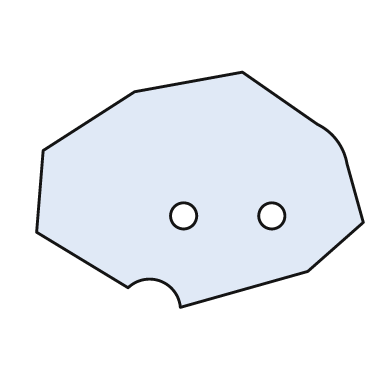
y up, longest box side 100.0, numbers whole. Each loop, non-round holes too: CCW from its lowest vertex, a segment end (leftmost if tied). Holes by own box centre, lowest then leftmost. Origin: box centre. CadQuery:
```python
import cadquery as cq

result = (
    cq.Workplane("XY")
    .moveTo(-6.0, -36.0)
    .lineTo(33.0, -25.0)
    .lineTo(50.0, -10.0)
    .lineTo(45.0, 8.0)
    .threePointArc((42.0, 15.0), (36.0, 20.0))
    .lineTo(13.0, 36.0)
    .lineTo(-20.0, 30.0)
    .lineTo(-48.0, 12.0)
    .lineTo(-50.0, -13.0)
    .lineTo(-22.0, -30.0)
    .threePointArc((-12.0, -28.0), (-6.0, -36.0))
    .close()
    .moveTo(-5.0, -8.0)
    .circle(4.0)
    .moveTo(22.0, -8.0)
    .circle(4.0)
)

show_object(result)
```